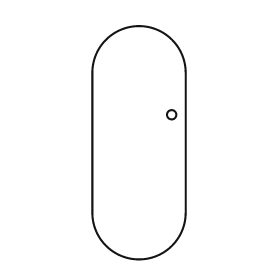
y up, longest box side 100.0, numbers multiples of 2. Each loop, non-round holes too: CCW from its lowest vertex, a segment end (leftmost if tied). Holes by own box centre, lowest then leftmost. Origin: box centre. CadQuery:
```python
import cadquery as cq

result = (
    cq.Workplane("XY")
    .moveTo(-20.0, -30.0)
    .threePointArc((0.0, -50.0), (20.0, -30.0))
    .lineTo(20.0, 30.0)
    .threePointArc((0.0, 50.0), (-20.0, 30.0))
    .close()
    .moveTo(14.0, 12.0)
    .circle(2.0)
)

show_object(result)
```